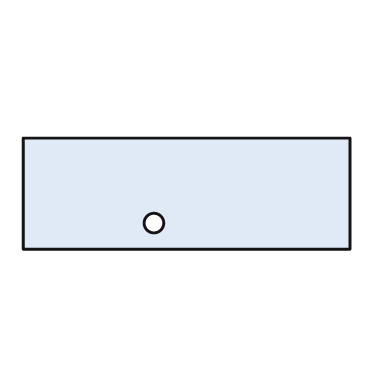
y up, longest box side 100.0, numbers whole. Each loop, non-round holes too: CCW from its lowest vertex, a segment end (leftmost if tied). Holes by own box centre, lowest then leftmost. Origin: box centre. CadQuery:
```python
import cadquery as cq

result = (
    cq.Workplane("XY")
    .moveTo(-50.0, -17.0)
    .lineTo(50.0, -17.0)
    .lineTo(50.0, 17.0)
    .lineTo(-50.0, 17.0)
    .close()
    .moveTo(-10.0, -9.0)
    .circle(3.0)
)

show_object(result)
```